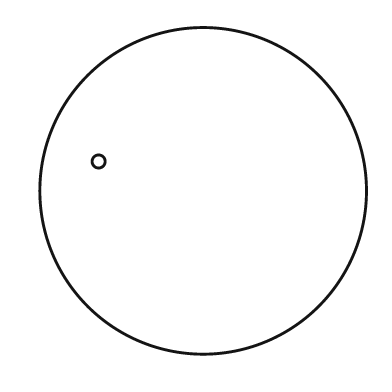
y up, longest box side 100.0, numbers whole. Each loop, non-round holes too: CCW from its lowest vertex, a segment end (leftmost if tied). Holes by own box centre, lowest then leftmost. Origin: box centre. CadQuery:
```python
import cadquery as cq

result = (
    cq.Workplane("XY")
    .moveTo(0.0, 0.0)
    .circle(50.0)
    .moveTo(-32.0, 9.0)
    .circle(2.0)
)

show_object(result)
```